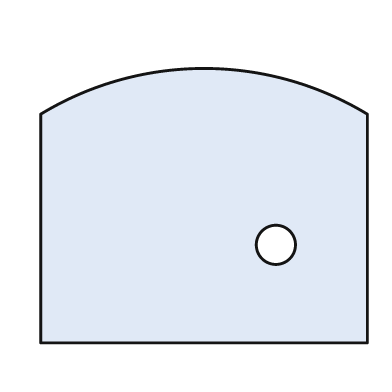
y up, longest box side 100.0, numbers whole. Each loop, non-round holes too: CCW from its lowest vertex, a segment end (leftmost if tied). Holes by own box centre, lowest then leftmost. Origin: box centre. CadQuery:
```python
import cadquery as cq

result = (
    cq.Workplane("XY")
    .moveTo(-50.0, -42.0)
    .lineTo(50.0, -42.0)
    .lineTo(50.0, 28.0)
    .threePointArc((0.0, 42.0), (-50.0, 28.0))
    .close()
    .moveTo(22.0, -12.0)
    .circle(6.0)
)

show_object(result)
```